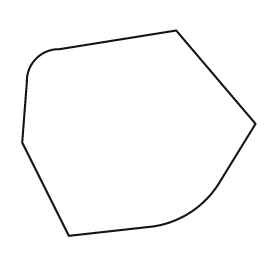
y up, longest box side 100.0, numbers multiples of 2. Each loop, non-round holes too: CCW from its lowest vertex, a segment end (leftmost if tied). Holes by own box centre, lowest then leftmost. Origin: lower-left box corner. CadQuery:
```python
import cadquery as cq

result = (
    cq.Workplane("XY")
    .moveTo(20.0, 0.0)
    .lineTo(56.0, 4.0)
    .threePointArc((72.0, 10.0), (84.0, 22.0))
    .lineTo(100.0, 48.0)
    .lineTo(66.0, 88.0)
    .lineTo(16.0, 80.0)
    .threePointArc((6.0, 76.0), (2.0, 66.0))
    .lineTo(0.0, 40.0)
    .close()
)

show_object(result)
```